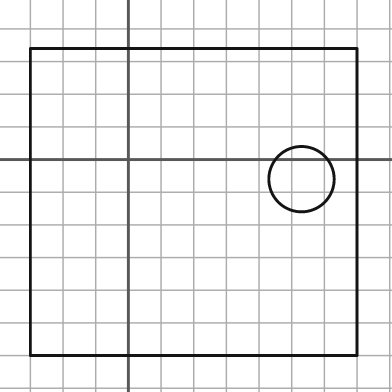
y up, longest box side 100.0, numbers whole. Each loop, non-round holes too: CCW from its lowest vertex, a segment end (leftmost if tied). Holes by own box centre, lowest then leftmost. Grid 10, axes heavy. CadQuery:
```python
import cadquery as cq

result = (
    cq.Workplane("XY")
    .moveTo(-30.0, -60.0)
    .lineTo(70.0, -60.0)
    .lineTo(70.0, 34.0)
    .lineTo(-30.0, 34.0)
    .close()
    .moveTo(53.0, -6.0)
    .circle(10.0)
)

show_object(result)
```